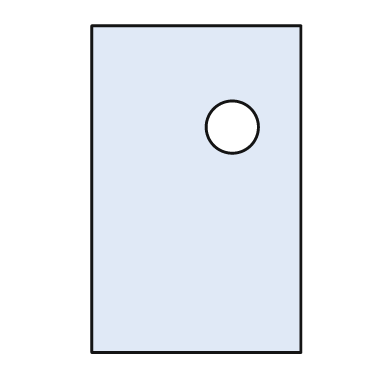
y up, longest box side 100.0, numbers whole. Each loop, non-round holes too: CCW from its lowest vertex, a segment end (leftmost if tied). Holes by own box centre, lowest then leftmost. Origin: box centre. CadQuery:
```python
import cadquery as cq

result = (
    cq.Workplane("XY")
    .moveTo(-32.0, -50.0)
    .lineTo(32.0, -50.0)
    .lineTo(32.0, 50.0)
    .lineTo(-32.0, 50.0)
    .close()
    .moveTo(11.0, 19.0)
    .circle(8.0)
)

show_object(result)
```